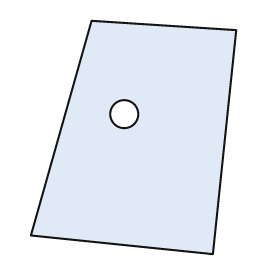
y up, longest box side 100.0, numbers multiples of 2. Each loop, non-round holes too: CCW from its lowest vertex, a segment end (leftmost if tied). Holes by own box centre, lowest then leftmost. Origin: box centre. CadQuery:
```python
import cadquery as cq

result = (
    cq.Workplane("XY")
    .moveTo(34.0, -50.0)
    .lineTo(44.0, 46.0)
    .lineTo(-18.0, 50.0)
    .lineTo(-44.0, -42.0)
    .close()
    .moveTo(-4.0, 10.0)
    .circle(6.0)
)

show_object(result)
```